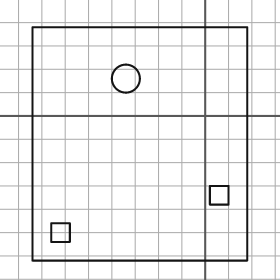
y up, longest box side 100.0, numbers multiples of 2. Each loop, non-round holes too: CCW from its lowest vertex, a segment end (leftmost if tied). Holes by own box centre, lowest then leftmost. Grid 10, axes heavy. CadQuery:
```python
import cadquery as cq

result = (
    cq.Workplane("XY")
    .moveTo(-74.0, -62.0)
    .lineTo(18.0, -62.0)
    .lineTo(18.0, 38.0)
    .lineTo(-74.0, 38.0)
    .close()
    .moveTo(-66.0, -54.0)
    .lineTo(-58.0, -54.0)
    .lineTo(-58.0, -46.0)
    .lineTo(-66.0, -46.0)
    .close()
    .moveTo(2.0, -38.0)
    .lineTo(10.0, -38.0)
    .lineTo(10.0, -30.0)
    .lineTo(2.0, -30.0)
    .close()
    .moveTo(-34.0, 16.0)
    .circle(6.0)
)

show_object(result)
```